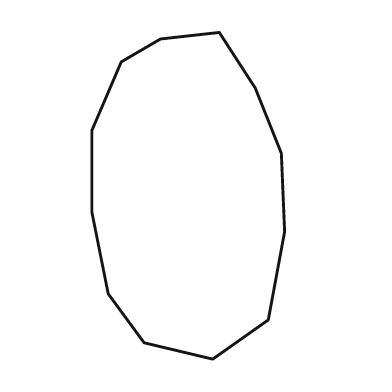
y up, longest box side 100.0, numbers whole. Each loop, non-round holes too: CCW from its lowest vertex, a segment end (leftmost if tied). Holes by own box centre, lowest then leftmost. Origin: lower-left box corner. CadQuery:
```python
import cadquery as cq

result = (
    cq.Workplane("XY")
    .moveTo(37.0, 0.0)
    .lineTo(54.0, 12.0)
    .lineTo(59.0, 39.0)
    .lineTo(58.0, 63.0)
    .lineTo(50.0, 83.0)
    .lineTo(39.0, 100.0)
    .lineTo(21.0, 98.0)
    .lineTo(9.0, 91.0)
    .lineTo(0.0, 70.0)
    .lineTo(0.0, 45.0)
    .lineTo(5.0, 20.0)
    .lineTo(16.0, 5.0)
    .close()
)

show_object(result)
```